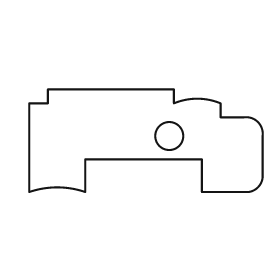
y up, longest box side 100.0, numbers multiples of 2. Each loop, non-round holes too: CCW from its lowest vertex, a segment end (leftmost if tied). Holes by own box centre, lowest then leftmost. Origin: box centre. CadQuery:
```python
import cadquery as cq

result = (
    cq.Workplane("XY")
    .moveTo(-50.0, -22.0)
    .threePointArc((-38.0, -20.0), (-26.0, -22.0))
    .lineTo(-26.0, -8.0)
    .lineTo(24.0, -8.0)
    .lineTo(24.0, -22.0)
    .lineTo(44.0, -22.0)
    .threePointArc((48.0, -20.0), (50.0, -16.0))
    .lineTo(50.0, 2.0)
    .threePointArc((48.0, 8.0), (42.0, 10.0))
    .lineTo(32.0, 10.0)
    .lineTo(32.0, 16.0)
    .threePointArc((22.0, 18.0), (12.0, 16.0))
    .lineTo(12.0, 22.0)
    .lineTo(-42.0, 22.0)
    .lineTo(-42.0, 16.0)
    .lineTo(-50.0, 16.0)
    .close()
    .moveTo(10.0, 2.0)
    .circle(6.0)
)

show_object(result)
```